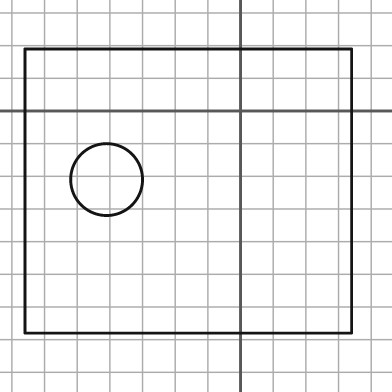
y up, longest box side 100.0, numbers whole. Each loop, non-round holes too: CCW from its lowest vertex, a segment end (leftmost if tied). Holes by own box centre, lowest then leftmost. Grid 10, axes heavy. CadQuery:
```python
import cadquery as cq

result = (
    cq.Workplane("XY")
    .moveTo(-66.0, -68.0)
    .lineTo(34.0, -68.0)
    .lineTo(34.0, 19.0)
    .lineTo(-66.0, 19.0)
    .close()
    .moveTo(-41.0, -21.0)
    .circle(11.0)
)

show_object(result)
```